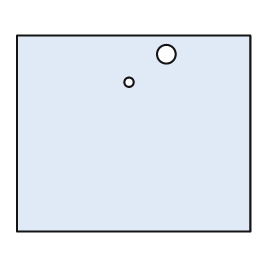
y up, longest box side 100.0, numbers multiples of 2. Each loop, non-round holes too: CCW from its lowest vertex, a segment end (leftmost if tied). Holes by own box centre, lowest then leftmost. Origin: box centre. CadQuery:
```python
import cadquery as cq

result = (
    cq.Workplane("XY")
    .moveTo(-50.0, -42.0)
    .lineTo(50.0, -42.0)
    .lineTo(50.0, 42.0)
    .lineTo(-50.0, 42.0)
    .close()
    .moveTo(-2.0, 22.0)
    .circle(2.0)
    .moveTo(14.0, 34.0)
    .circle(4.0)
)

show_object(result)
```